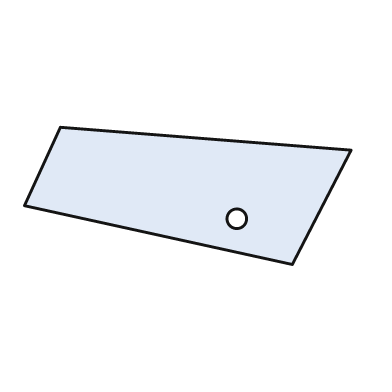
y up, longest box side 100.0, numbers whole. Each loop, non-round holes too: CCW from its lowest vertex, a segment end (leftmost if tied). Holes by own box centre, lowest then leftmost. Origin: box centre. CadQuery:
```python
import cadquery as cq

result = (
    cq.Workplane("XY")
    .moveTo(32.0, -21.0)
    .lineTo(50.0, 14.0)
    .lineTo(-39.0, 21.0)
    .lineTo(-50.0, -3.0)
    .close()
    .moveTo(15.0, -7.0)
    .circle(3.0)
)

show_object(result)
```